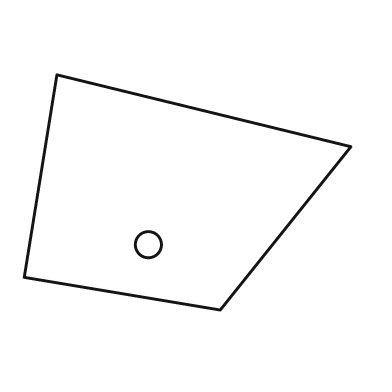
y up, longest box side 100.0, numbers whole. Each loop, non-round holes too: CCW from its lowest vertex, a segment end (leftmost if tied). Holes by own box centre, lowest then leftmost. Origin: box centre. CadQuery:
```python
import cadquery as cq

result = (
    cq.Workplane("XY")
    .moveTo(10.0, -36.0)
    .lineTo(50.0, 14.0)
    .lineTo(-40.0, 36.0)
    .lineTo(-50.0, -26.0)
    .close()
    .moveTo(-12.0, -16.0)
    .circle(4.0)
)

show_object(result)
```